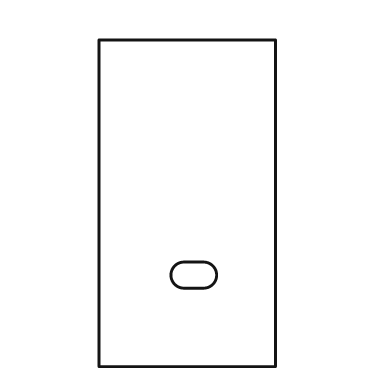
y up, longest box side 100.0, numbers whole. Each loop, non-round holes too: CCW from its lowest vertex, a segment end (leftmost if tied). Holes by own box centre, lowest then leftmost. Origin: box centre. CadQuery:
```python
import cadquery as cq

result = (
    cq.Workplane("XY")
    .moveTo(-27.0, -50.0)
    .lineTo(27.0, -50.0)
    .lineTo(27.0, 50.0)
    .lineTo(-27.0, 50.0)
    .close()
    .moveTo(-1.0, -26.0)
    .lineTo(5.0, -26.0)
    .threePointArc((9.0, -22.0), (5.0, -18.0))
    .lineTo(-1.0, -18.0)
    .threePointArc((-5.0, -22.0), (-1.0, -26.0))
    .close()
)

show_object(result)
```